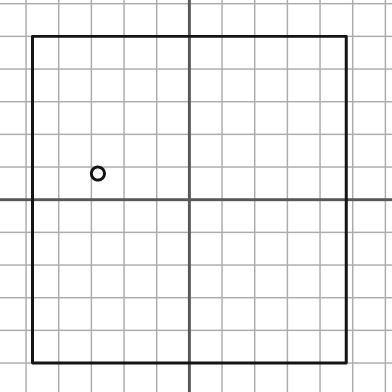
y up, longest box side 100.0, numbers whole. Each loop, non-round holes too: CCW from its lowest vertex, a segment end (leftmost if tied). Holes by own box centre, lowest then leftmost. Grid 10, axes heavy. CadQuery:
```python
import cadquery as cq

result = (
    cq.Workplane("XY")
    .moveTo(-48.0, -50.0)
    .lineTo(48.0, -50.0)
    .lineTo(48.0, 50.0)
    .lineTo(-48.0, 50.0)
    .close()
    .moveTo(-28.0, 8.0)
    .circle(2.0)
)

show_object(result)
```